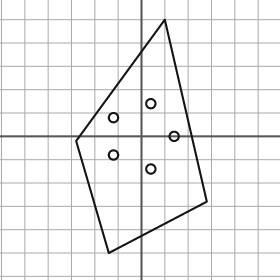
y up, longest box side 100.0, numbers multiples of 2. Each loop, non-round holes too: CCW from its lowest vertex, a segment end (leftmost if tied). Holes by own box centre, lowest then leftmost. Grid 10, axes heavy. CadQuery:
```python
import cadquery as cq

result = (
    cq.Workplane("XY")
    .moveTo(-14.0, -50.0)
    .lineTo(28.0, -28.0)
    .lineTo(10.0, 50.0)
    .lineTo(-28.0, -2.0)
    .close()
    .moveTo(4.0, -14.0)
    .circle(2.0)
    .moveTo(-12.0, -8.0)
    .circle(2.0)
    .moveTo(14.0, 0.0)
    .circle(2.0)
    .moveTo(-12.0, 8.0)
    .circle(2.0)
    .moveTo(4.0, 14.0)
    .circle(2.0)
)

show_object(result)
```